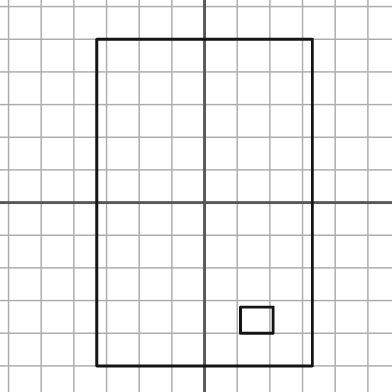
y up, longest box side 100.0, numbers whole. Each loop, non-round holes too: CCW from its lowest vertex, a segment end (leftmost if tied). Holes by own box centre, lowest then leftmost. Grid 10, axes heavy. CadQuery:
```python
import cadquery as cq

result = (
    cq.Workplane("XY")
    .moveTo(-33.0, -50.0)
    .lineTo(33.0, -50.0)
    .lineTo(33.0, 50.0)
    .lineTo(-33.0, 50.0)
    .close()
    .moveTo(11.0, -40.0)
    .lineTo(21.0, -40.0)
    .lineTo(21.0, -32.0)
    .lineTo(11.0, -32.0)
    .close()
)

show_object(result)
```